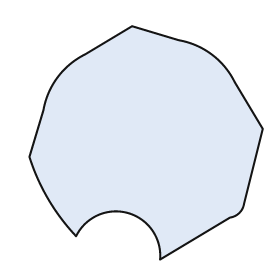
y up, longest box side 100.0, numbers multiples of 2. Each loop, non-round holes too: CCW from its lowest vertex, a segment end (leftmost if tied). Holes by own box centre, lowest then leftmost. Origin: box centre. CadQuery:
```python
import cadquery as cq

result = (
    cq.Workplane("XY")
    .moveTo(6.0, -50.0)
    .lineTo(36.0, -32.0)
    .threePointArc((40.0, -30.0), (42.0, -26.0))
    .lineTo(50.0, 6.0)
    .lineTo(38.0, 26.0)
    .threePointArc((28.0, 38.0), (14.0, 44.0))
    .lineTo(-6.0, 50.0)
    .lineTo(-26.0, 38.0)
    .threePointArc((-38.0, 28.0), (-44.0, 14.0))
    .lineTo(-50.0, -6.0)
    .threePointArc((-42.0, -24.0), (-30.0, -40.0))
    .threePointArc((-8.0, -30.0), (6.0, -50.0))
    .close()
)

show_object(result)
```